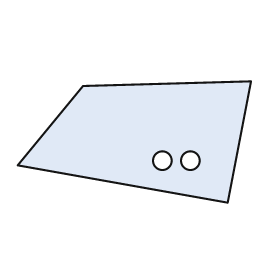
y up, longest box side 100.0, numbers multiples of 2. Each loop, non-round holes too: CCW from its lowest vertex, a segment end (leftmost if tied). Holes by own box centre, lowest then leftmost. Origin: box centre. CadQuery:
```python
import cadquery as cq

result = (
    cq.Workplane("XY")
    .moveTo(40.0, -26.0)
    .lineTo(50.0, 26.0)
    .lineTo(-22.0, 24.0)
    .lineTo(-50.0, -10.0)
    .close()
    .moveTo(12.0, -8.0)
    .circle(4.0)
    .moveTo(24.0, -8.0)
    .circle(4.0)
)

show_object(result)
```